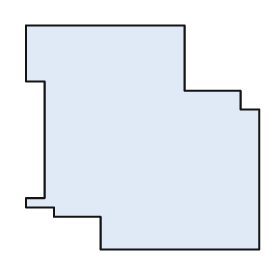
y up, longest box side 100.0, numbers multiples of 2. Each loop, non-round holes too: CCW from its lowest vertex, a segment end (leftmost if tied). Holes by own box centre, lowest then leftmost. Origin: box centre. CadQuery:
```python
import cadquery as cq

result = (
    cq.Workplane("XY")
    .moveTo(-18.0, -48.0)
    .lineTo(50.0, -48.0)
    .lineTo(50.0, 12.0)
    .lineTo(42.0, 12.0)
    .lineTo(42.0, 20.0)
    .lineTo(18.0, 20.0)
    .lineTo(18.0, 48.0)
    .lineTo(-50.0, 48.0)
    .lineTo(-50.0, 24.0)
    .lineTo(-42.0, 24.0)
    .lineTo(-42.0, -26.0)
    .lineTo(-50.0, -26.0)
    .lineTo(-50.0, -30.0)
    .lineTo(-38.0, -30.0)
    .lineTo(-38.0, -34.0)
    .lineTo(-18.0, -34.0)
    .close()
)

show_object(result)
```